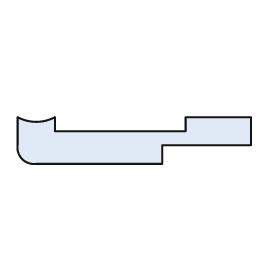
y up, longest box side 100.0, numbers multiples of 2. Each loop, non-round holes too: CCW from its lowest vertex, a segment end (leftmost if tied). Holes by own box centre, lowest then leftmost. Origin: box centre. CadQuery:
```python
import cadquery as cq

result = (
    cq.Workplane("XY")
    .moveTo(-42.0, -10.0)
    .lineTo(12.0, -10.0)
    .lineTo(12.0, -2.0)
    .lineTo(50.0, -2.0)
    .lineTo(50.0, 10.0)
    .lineTo(22.0, 10.0)
    .lineTo(22.0, 4.0)
    .lineTo(-34.0, 4.0)
    .lineTo(-34.0, 10.0)
    .threePointArc((-42.0, 8.0), (-50.0, 10.0))
    .lineTo(-50.0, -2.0)
    .threePointArc((-48.0, -8.0), (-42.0, -10.0))
    .close()
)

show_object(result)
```